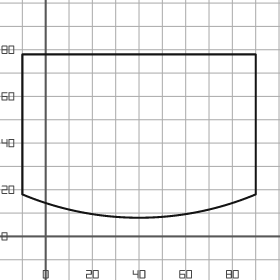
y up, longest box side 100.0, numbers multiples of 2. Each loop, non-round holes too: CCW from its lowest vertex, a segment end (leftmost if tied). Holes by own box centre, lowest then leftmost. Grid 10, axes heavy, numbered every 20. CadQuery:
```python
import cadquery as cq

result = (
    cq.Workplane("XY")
    .moveTo(-10.0, 18.0)
    .threePointArc((40.0, 8.0), (90.0, 18.0))
    .lineTo(90.0, 78.0)
    .lineTo(-10.0, 78.0)
    .close()
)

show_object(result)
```